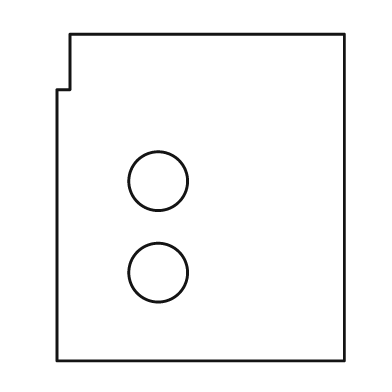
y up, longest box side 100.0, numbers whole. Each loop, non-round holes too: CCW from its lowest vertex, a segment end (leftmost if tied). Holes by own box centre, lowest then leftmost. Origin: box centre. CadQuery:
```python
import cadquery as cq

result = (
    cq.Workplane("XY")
    .moveTo(-44.0, -50.0)
    .lineTo(44.0, -50.0)
    .lineTo(44.0, 50.0)
    .lineTo(-40.0, 50.0)
    .lineTo(-40.0, 33.0)
    .lineTo(-44.0, 33.0)
    .close()
    .moveTo(-13.0, -23.0)
    .circle(9.0)
    .moveTo(-13.0, 5.0)
    .circle(9.0)
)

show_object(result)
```